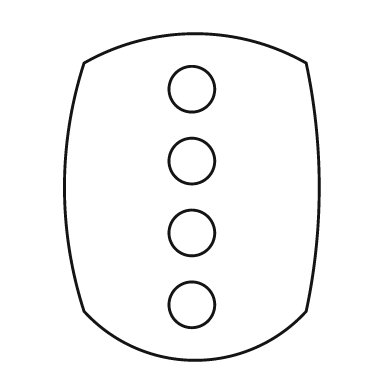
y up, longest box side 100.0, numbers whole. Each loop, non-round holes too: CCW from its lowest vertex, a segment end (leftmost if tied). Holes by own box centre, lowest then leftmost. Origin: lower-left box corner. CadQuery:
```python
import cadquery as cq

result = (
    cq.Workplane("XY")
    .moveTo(6.0, 15.0)
    .threePointArc((40.0, 0.0), (74.0, 15.0))
    .threePointArc((78.0, 53.0), (74.0, 91.0))
    .threePointArc((40.0, 100.0), (6.0, 91.0))
    .threePointArc((0.0, 53.0), (6.0, 15.0))
    .close()
    .moveTo(39.0, 17.0)
    .circle(7.0)
    .moveTo(39.0, 39.0)
    .circle(7.0)
    .moveTo(39.0, 61.0)
    .circle(7.0)
    .moveTo(39.0, 83.0)
    .circle(7.0)
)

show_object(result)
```